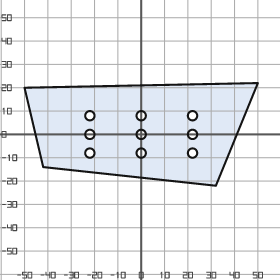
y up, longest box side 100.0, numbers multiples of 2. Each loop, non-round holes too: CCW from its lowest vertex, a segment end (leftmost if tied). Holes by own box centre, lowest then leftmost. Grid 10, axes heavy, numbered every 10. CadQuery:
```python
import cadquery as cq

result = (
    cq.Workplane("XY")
    .moveTo(32.0, -22.0)
    .lineTo(50.0, 22.0)
    .lineTo(-50.0, 20.0)
    .lineTo(-42.0, -14.0)
    .close()
    .moveTo(-22.0, -8.0)
    .circle(2.0)
    .moveTo(0.0, -8.0)
    .circle(2.0)
    .moveTo(22.0, -8.0)
    .circle(2.0)
    .moveTo(-22.0, 0.0)
    .circle(2.0)
    .moveTo(0.0, 0.0)
    .circle(2.0)
    .moveTo(22.0, 0.0)
    .circle(2.0)
    .moveTo(-22.0, 8.0)
    .circle(2.0)
    .moveTo(0.0, 8.0)
    .circle(2.0)
    .moveTo(22.0, 8.0)
    .circle(2.0)
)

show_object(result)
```